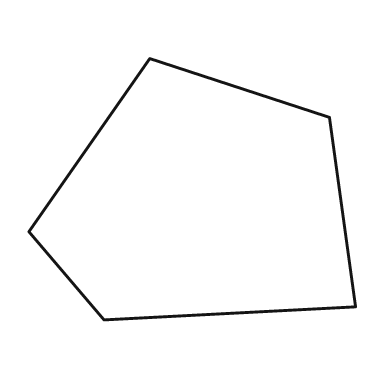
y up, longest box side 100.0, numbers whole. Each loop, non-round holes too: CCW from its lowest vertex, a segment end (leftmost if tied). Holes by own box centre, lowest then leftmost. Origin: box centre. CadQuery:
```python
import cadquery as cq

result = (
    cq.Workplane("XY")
    .moveTo(-27.0, -40.0)
    .lineTo(50.0, -36.0)
    .lineTo(42.0, 22.0)
    .lineTo(-13.0, 40.0)
    .lineTo(-50.0, -13.0)
    .close()
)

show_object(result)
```